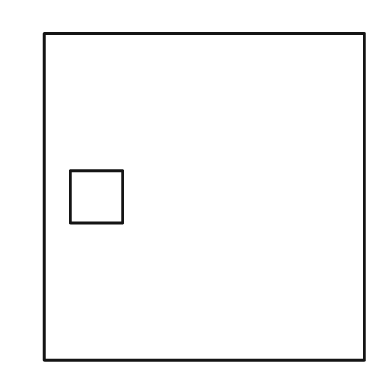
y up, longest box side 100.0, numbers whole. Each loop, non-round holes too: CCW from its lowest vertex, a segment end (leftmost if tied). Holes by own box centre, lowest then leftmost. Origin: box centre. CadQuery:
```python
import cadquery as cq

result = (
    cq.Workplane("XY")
    .moveTo(-49.0, -50.0)
    .lineTo(49.0, -50.0)
    .lineTo(49.0, 50.0)
    .lineTo(-49.0, 50.0)
    .close()
    .moveTo(-41.0, -8.0)
    .lineTo(-25.0, -8.0)
    .lineTo(-25.0, 8.0)
    .lineTo(-41.0, 8.0)
    .close()
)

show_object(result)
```